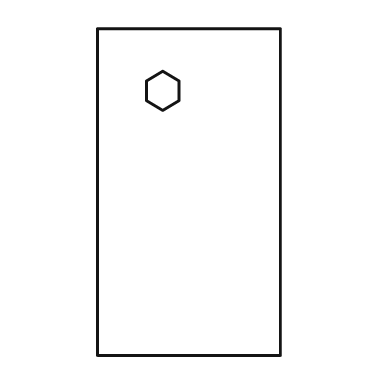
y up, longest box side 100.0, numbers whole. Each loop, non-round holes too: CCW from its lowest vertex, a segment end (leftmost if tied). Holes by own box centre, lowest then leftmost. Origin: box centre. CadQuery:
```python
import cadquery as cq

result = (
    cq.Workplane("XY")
    .moveTo(-28.0, -50.0)
    .lineTo(28.0, -50.0)
    .lineTo(28.0, 50.0)
    .lineTo(-28.0, 50.0)
    .close()
    .moveTo(-8.0, 25.0)
    .lineTo(-3.0, 28.0)
    .lineTo(-3.0, 34.0)
    .lineTo(-8.0, 37.0)
    .lineTo(-13.0, 34.0)
    .lineTo(-13.0, 28.0)
    .close()
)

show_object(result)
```